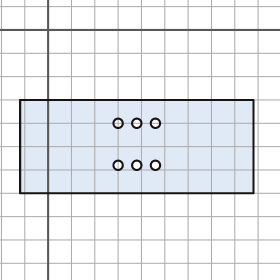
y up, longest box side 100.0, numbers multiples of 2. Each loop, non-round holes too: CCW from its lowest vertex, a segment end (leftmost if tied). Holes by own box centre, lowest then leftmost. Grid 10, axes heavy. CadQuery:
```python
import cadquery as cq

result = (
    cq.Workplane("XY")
    .moveTo(-12.0, -70.0)
    .lineTo(88.0, -70.0)
    .lineTo(88.0, -30.0)
    .lineTo(-12.0, -30.0)
    .close()
    .moveTo(30.0, -58.0)
    .circle(2.0)
    .moveTo(38.0, -58.0)
    .circle(2.0)
    .moveTo(46.0, -58.0)
    .circle(2.0)
    .moveTo(30.0, -40.0)
    .circle(2.0)
    .moveTo(38.0, -40.0)
    .circle(2.0)
    .moveTo(46.0, -40.0)
    .circle(2.0)
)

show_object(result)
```